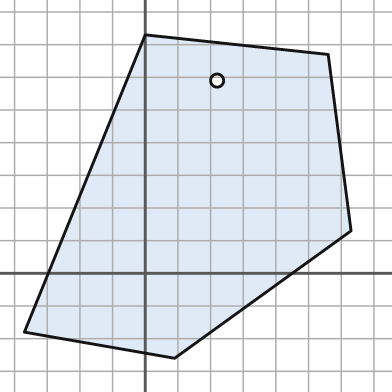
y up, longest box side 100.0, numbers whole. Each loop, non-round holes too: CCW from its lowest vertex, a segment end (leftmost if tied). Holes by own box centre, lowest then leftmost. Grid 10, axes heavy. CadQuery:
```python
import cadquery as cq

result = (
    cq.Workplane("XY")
    .moveTo(9.0, -26.0)
    .lineTo(63.0, 13.0)
    .lineTo(56.0, 67.0)
    .lineTo(0.0, 73.0)
    .lineTo(-37.0, -18.0)
    .close()
    .moveTo(22.0, 59.0)
    .circle(2.0)
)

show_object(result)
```